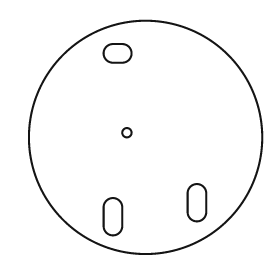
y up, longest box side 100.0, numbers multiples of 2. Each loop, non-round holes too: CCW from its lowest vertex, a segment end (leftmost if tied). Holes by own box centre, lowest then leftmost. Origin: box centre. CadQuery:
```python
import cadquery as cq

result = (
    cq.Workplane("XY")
    .moveTo(0.0, 0.0)
    .circle(50.0)
    .moveTo(-18.0, -38.0)
    .threePointArc((-14.0, -42.0), (-10.0, -38.0))
    .lineTo(-10.0, -30.0)
    .threePointArc((-14.0, -26.0), (-18.0, -30.0))
    .close()
    .moveTo(18.0, -32.0)
    .threePointArc((22.0, -36.0), (26.0, -32.0))
    .lineTo(26.0, -24.0)
    .threePointArc((22.0, -20.0), (18.0, -24.0))
    .close()
    .moveTo(-8.0, 2.0)
    .circle(2.0)
    .moveTo(-14.0, 32.0)
    .lineTo(-10.0, 32.0)
    .threePointArc((-6.0, 36.0), (-10.0, 40.0))
    .lineTo(-14.0, 40.0)
    .threePointArc((-18.0, 36.0), (-14.0, 32.0))
    .close()
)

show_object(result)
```